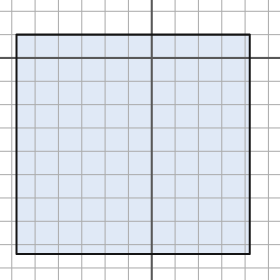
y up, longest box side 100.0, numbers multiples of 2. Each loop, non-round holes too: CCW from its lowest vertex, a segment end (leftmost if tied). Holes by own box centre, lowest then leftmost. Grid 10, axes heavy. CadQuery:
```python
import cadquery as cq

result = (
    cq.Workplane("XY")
    .moveTo(-58.0, -84.0)
    .lineTo(42.0, -84.0)
    .lineTo(42.0, 10.0)
    .lineTo(-58.0, 10.0)
    .close()
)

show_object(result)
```